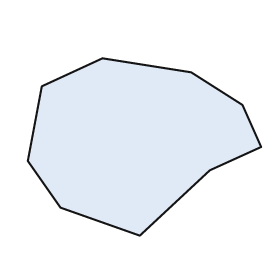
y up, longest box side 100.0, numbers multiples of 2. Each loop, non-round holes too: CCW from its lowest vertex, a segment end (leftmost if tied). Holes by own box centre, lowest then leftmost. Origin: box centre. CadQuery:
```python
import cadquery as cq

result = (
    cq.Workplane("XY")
    .moveTo(-2.0, -38.0)
    .lineTo(28.0, -10.0)
    .lineTo(50.0, 0.0)
    .lineTo(42.0, 18.0)
    .lineTo(20.0, 32.0)
    .lineTo(-18.0, 38.0)
    .lineTo(-44.0, 26.0)
    .lineTo(-50.0, -6.0)
    .lineTo(-36.0, -26.0)
    .close()
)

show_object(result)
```